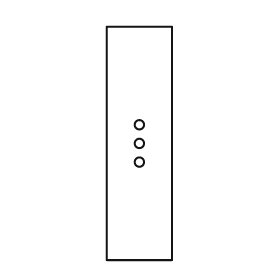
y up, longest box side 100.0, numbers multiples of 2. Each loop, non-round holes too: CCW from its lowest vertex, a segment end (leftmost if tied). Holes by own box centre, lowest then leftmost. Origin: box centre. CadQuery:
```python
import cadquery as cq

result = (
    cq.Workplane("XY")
    .moveTo(-14.0, -50.0)
    .lineTo(14.0, -50.0)
    .lineTo(14.0, 50.0)
    .lineTo(-14.0, 50.0)
    .close()
    .moveTo(0.0, -8.0)
    .circle(2.0)
    .moveTo(0.0, 0.0)
    .circle(2.0)
    .moveTo(0.0, 8.0)
    .circle(2.0)
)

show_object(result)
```